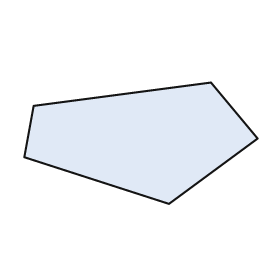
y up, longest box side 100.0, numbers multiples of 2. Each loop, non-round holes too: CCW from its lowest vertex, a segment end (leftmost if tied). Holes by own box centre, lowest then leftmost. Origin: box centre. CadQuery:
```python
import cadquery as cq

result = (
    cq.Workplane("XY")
    .moveTo(12.0, -26.0)
    .lineTo(50.0, 2.0)
    .lineTo(30.0, 26.0)
    .lineTo(-46.0, 16.0)
    .lineTo(-50.0, -6.0)
    .close()
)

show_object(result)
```